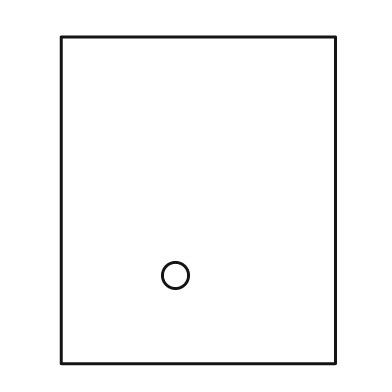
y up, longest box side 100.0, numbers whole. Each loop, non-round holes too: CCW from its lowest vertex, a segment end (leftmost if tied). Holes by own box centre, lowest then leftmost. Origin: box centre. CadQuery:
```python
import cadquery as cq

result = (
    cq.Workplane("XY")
    .moveTo(-42.0, -50.0)
    .lineTo(42.0, -50.0)
    .lineTo(42.0, 50.0)
    .lineTo(-42.0, 50.0)
    .close()
    .moveTo(-7.0, -23.0)
    .circle(4.0)
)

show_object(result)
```